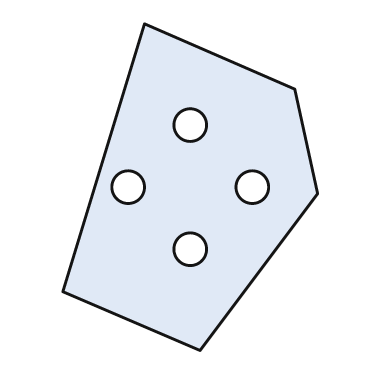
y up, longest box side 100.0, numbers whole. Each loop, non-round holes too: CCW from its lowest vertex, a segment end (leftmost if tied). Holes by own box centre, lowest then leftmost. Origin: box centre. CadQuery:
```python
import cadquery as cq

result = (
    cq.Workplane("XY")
    .moveTo(3.0, -50.0)
    .lineTo(39.0, -2.0)
    .lineTo(32.0, 30.0)
    .lineTo(-14.0, 50.0)
    .lineTo(-39.0, -32.0)
    .close()
    .moveTo(0.0, -19.0)
    .circle(5.0)
    .moveTo(-19.0, 0.0)
    .circle(5.0)
    .moveTo(19.0, 0.0)
    .circle(5.0)
    .moveTo(0.0, 19.0)
    .circle(5.0)
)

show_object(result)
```